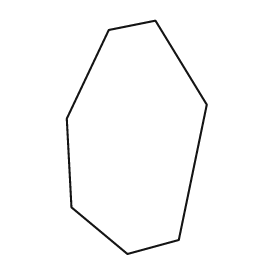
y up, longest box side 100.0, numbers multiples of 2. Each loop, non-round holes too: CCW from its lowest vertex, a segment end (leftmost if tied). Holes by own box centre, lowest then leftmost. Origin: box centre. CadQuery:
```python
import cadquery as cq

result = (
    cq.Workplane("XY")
    .moveTo(-4.0, -50.0)
    .lineTo(18.0, -44.0)
    .lineTo(30.0, 14.0)
    .lineTo(8.0, 50.0)
    .lineTo(-12.0, 46.0)
    .lineTo(-30.0, 8.0)
    .lineTo(-28.0, -30.0)
    .close()
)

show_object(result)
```